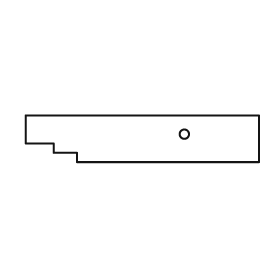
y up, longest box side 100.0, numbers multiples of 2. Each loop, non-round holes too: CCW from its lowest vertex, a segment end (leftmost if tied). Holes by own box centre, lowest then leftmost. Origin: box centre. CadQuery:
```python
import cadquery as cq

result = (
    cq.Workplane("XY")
    .moveTo(-28.0, -10.0)
    .lineTo(50.0, -10.0)
    .lineTo(50.0, 10.0)
    .lineTo(-50.0, 10.0)
    .lineTo(-50.0, -2.0)
    .lineTo(-38.0, -2.0)
    .lineTo(-38.0, -6.0)
    .lineTo(-28.0, -6.0)
    .close()
    .moveTo(18.0, 2.0)
    .circle(2.0)
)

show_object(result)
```